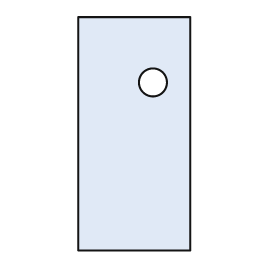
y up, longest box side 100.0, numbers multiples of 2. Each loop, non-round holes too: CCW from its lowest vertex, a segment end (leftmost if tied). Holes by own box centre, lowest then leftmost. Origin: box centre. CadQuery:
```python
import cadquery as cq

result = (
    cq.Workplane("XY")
    .moveTo(-24.0, -50.0)
    .lineTo(24.0, -50.0)
    .lineTo(24.0, 50.0)
    .lineTo(-24.0, 50.0)
    .close()
    .moveTo(8.0, 22.0)
    .circle(6.0)
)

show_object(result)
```